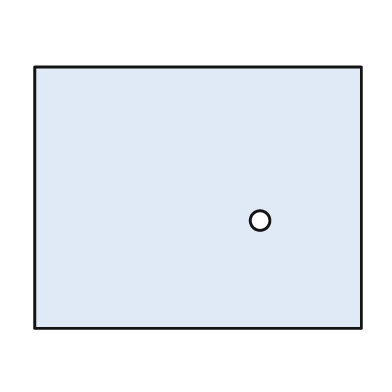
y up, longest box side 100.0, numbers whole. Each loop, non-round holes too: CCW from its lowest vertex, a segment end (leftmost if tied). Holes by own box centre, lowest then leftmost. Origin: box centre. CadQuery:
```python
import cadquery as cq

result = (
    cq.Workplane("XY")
    .moveTo(-50.0, -40.0)
    .lineTo(50.0, -40.0)
    .lineTo(50.0, 40.0)
    .lineTo(-50.0, 40.0)
    .close()
    .moveTo(19.0, -7.0)
    .circle(3.0)
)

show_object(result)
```